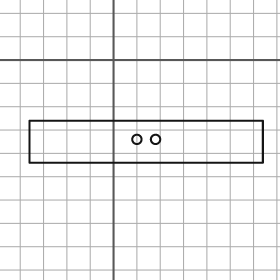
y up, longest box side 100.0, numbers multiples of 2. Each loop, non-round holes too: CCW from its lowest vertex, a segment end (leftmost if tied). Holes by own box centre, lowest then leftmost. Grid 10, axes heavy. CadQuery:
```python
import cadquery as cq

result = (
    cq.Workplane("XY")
    .moveTo(-36.0, -44.0)
    .lineTo(64.0, -44.0)
    .lineTo(64.0, -26.0)
    .lineTo(-36.0, -26.0)
    .close()
    .moveTo(10.0, -34.0)
    .circle(2.0)
    .moveTo(18.0, -34.0)
    .circle(2.0)
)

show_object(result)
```